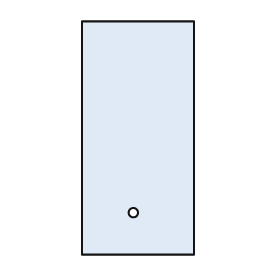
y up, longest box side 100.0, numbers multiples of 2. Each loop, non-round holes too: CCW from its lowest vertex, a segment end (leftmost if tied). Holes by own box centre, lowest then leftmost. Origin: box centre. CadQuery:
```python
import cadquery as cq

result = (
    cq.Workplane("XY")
    .moveTo(-24.0, -50.0)
    .lineTo(24.0, -50.0)
    .lineTo(24.0, 50.0)
    .lineTo(-24.0, 50.0)
    .close()
    .moveTo(-2.0, -32.0)
    .circle(2.0)
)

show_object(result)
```